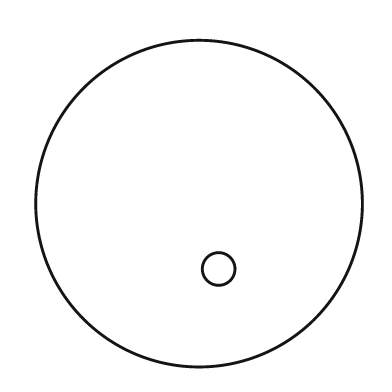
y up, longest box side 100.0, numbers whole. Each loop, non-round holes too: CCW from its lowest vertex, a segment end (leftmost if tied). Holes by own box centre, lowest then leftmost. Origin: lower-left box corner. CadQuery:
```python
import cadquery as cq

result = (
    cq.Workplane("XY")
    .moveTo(50.0, 50.0)
    .circle(50.0)
    .moveTo(56.0, 30.0)
    .circle(5.0)
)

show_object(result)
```